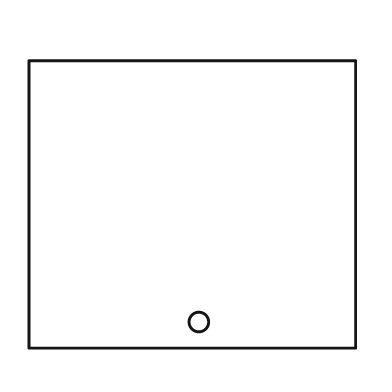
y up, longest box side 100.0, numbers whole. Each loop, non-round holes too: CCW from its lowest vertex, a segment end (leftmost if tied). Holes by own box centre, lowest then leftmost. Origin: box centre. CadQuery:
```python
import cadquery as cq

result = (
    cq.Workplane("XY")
    .moveTo(-50.0, -44.0)
    .lineTo(50.0, -44.0)
    .lineTo(50.0, 44.0)
    .lineTo(-50.0, 44.0)
    .close()
    .moveTo(2.0, -36.0)
    .circle(3.0)
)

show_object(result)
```